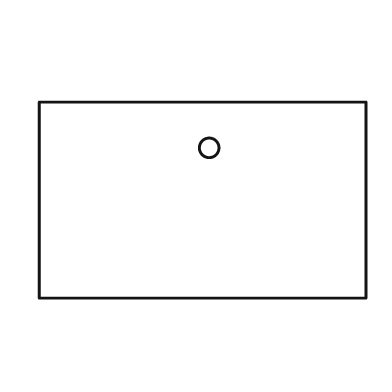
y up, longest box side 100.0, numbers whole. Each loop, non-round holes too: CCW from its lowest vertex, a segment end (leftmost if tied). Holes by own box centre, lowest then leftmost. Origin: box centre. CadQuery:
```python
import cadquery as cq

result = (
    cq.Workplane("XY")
    .moveTo(-50.0, -30.0)
    .lineTo(50.0, -30.0)
    .lineTo(50.0, 30.0)
    .lineTo(-50.0, 30.0)
    .close()
    .moveTo(2.0, 16.0)
    .circle(3.0)
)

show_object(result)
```